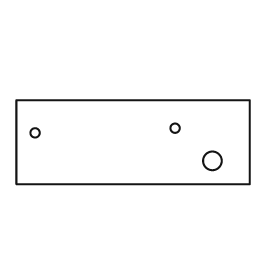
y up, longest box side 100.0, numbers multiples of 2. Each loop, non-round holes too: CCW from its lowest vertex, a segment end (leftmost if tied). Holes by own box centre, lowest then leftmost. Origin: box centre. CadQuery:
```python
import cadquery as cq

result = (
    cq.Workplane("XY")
    .moveTo(-50.0, -18.0)
    .lineTo(50.0, -18.0)
    .lineTo(50.0, 18.0)
    .lineTo(-50.0, 18.0)
    .close()
    .moveTo(34.0, -8.0)
    .circle(4.0)
    .moveTo(-42.0, 4.0)
    .circle(2.0)
    .moveTo(18.0, 6.0)
    .circle(2.0)
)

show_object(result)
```